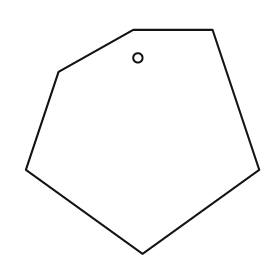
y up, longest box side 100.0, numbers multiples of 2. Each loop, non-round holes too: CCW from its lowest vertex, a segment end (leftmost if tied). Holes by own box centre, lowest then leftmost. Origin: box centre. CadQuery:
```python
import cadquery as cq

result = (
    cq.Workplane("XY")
    .moveTo(0.0, -48.0)
    .lineTo(50.0, -12.0)
    .lineTo(30.0, 48.0)
    .lineTo(-4.0, 48.0)
    .lineTo(-36.0, 30.0)
    .lineTo(-50.0, -12.0)
    .close()
    .moveTo(-2.0, 36.0)
    .circle(2.0)
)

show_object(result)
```